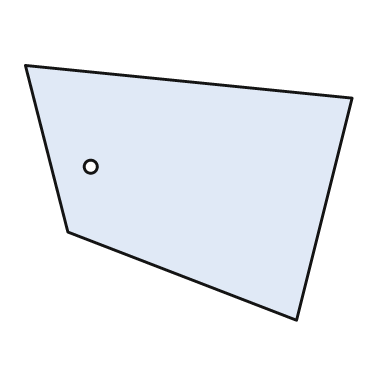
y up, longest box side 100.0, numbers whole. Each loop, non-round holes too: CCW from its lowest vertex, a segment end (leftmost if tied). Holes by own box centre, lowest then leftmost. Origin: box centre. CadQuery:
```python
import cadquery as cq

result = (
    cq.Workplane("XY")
    .moveTo(33.0, -39.0)
    .lineTo(50.0, 29.0)
    .lineTo(-50.0, 39.0)
    .lineTo(-37.0, -12.0)
    .close()
    .moveTo(-30.0, 8.0)
    .circle(2.0)
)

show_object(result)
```